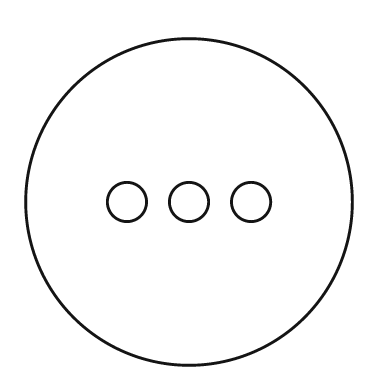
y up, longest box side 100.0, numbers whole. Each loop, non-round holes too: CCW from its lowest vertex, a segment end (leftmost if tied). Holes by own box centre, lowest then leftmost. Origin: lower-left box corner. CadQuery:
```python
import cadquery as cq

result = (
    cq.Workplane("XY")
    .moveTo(50.0, 50.0)
    .circle(50.0)
    .moveTo(31.0, 50.0)
    .circle(6.0)
    .moveTo(50.0, 50.0)
    .circle(6.0)
    .moveTo(69.0, 50.0)
    .circle(6.0)
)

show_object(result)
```